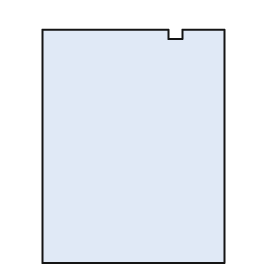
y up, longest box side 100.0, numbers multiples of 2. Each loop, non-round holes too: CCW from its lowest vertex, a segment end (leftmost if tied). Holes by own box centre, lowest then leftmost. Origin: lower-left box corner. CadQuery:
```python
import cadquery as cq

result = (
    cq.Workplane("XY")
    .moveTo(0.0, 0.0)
    .lineTo(78.0, 0.0)
    .lineTo(78.0, 100.0)
    .lineTo(60.0, 100.0)
    .lineTo(60.0, 96.0)
    .lineTo(54.0, 96.0)
    .lineTo(54.0, 100.0)
    .lineTo(0.0, 100.0)
    .close()
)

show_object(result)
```